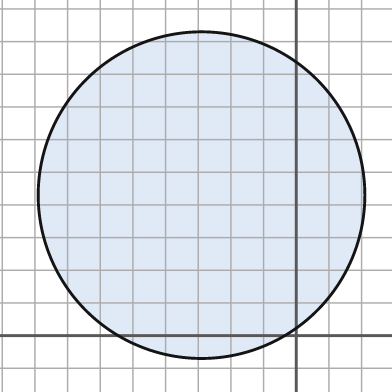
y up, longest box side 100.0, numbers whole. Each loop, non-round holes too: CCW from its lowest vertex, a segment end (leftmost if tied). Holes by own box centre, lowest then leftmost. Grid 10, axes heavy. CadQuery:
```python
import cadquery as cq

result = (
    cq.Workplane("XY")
    .moveTo(-29.0, 43.0)
    .circle(50.0)
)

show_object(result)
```